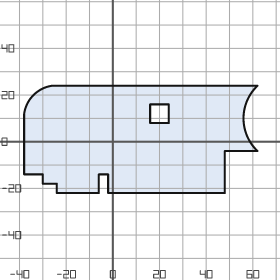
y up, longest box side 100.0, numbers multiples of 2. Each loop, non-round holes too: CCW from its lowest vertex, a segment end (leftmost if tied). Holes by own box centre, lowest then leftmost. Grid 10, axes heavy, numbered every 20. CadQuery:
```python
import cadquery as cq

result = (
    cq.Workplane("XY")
    .moveTo(-24.0, -22.0)
    .lineTo(-6.0, -22.0)
    .lineTo(-6.0, -14.0)
    .lineTo(-2.0, -14.0)
    .lineTo(-2.0, -22.0)
    .lineTo(48.0, -22.0)
    .lineTo(48.0, -4.0)
    .lineTo(62.0, -4.0)
    .threePointArc((56.0, 10.0), (62.0, 24.0))
    .lineTo(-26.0, 24.0)
    .threePointArc((-34.0, 20.0), (-38.0, 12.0))
    .lineTo(-38.0, -14.0)
    .lineTo(-30.0, -14.0)
    .lineTo(-30.0, -18.0)
    .lineTo(-24.0, -18.0)
    .close()
    .moveTo(16.0, 8.0)
    .lineTo(24.0, 8.0)
    .lineTo(24.0, 16.0)
    .lineTo(16.0, 16.0)
    .close()
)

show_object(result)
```